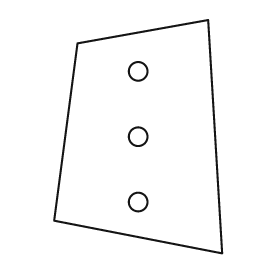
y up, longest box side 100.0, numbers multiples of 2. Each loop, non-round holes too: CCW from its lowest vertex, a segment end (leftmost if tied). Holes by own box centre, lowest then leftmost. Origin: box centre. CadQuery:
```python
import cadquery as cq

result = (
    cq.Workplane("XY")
    .moveTo(36.0, -50.0)
    .lineTo(30.0, 50.0)
    .lineTo(-26.0, 40.0)
    .lineTo(-36.0, -36.0)
    .close()
    .moveTo(0.0, -28.0)
    .circle(4.0)
    .moveTo(0.0, 0.0)
    .circle(4.0)
    .moveTo(0.0, 28.0)
    .circle(4.0)
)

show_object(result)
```